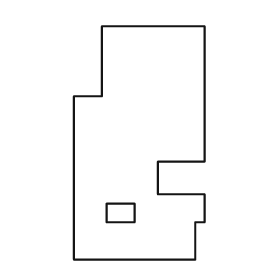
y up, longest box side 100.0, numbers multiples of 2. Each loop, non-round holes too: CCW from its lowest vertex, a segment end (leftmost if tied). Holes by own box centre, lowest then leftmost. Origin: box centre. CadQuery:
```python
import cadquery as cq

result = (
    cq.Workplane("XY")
    .moveTo(-28.0, -50.0)
    .lineTo(24.0, -50.0)
    .lineTo(24.0, -34.0)
    .lineTo(28.0, -34.0)
    .lineTo(28.0, -22.0)
    .lineTo(8.0, -22.0)
    .lineTo(8.0, -8.0)
    .lineTo(28.0, -8.0)
    .lineTo(28.0, 50.0)
    .lineTo(-16.0, 50.0)
    .lineTo(-16.0, 20.0)
    .lineTo(-28.0, 20.0)
    .close()
    .moveTo(-14.0, -34.0)
    .lineTo(-2.0, -34.0)
    .lineTo(-2.0, -26.0)
    .lineTo(-14.0, -26.0)
    .close()
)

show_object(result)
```